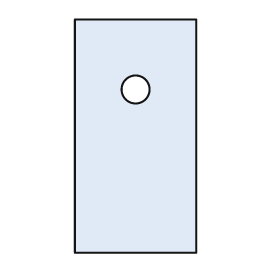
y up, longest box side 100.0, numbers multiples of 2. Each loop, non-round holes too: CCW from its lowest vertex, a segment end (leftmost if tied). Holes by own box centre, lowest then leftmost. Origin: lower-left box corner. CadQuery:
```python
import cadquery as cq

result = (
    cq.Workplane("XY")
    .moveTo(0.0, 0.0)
    .lineTo(52.0, 0.0)
    .lineTo(52.0, 100.0)
    .lineTo(0.0, 100.0)
    .close()
    .moveTo(26.0, 70.0)
    .circle(6.0)
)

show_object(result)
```